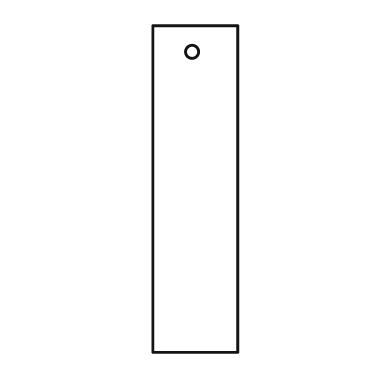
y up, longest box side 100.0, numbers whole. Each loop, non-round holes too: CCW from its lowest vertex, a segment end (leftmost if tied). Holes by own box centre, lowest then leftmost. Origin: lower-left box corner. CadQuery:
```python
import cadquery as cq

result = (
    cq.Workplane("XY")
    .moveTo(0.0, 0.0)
    .lineTo(26.0, 0.0)
    .lineTo(26.0, 100.0)
    .lineTo(0.0, 100.0)
    .close()
    .moveTo(12.0, 92.0)
    .circle(2.0)
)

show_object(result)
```